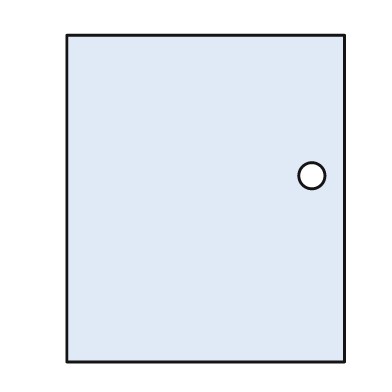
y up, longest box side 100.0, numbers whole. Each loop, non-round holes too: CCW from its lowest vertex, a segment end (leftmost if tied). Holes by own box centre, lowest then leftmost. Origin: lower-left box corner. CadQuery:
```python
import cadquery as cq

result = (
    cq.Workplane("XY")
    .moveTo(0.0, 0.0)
    .lineTo(85.0, 0.0)
    .lineTo(85.0, 100.0)
    .lineTo(0.0, 100.0)
    .close()
    .moveTo(75.0, 57.0)
    .circle(4.0)
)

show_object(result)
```